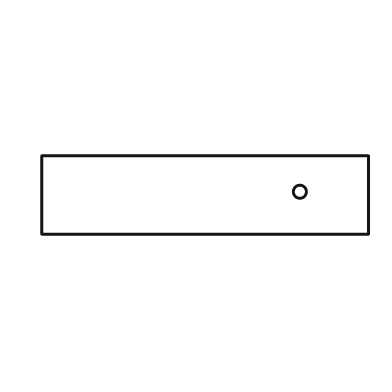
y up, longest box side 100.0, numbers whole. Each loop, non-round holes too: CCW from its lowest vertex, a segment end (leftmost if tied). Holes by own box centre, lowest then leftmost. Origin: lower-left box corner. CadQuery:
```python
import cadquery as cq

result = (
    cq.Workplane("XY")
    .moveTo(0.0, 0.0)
    .lineTo(100.0, 0.0)
    .lineTo(100.0, 24.0)
    .lineTo(0.0, 24.0)
    .close()
    .moveTo(79.0, 13.0)
    .circle(2.0)
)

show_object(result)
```